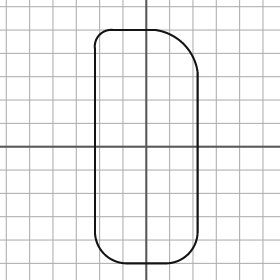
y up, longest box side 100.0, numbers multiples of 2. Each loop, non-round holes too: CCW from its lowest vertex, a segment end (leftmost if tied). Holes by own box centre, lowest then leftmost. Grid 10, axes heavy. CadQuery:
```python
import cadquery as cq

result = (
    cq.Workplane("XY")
    .moveTo(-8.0, -50.0)
    .lineTo(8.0, -50.0)
    .threePointArc((18.0, -46.0), (22.0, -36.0))
    .lineTo(22.0, 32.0)
    .threePointArc((16.0, 44.0), (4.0, 50.0))
    .lineTo(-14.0, 50.0)
    .threePointArc((-20.0, 48.0), (-22.0, 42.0))
    .lineTo(-22.0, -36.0)
    .threePointArc((-18.0, -46.0), (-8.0, -50.0))
    .close()
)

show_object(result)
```